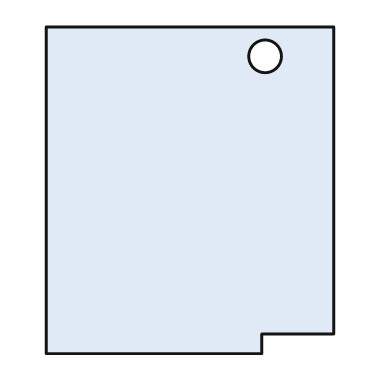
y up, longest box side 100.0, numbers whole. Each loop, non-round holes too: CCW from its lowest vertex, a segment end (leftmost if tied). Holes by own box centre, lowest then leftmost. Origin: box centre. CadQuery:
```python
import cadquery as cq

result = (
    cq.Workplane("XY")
    .moveTo(-44.0, -50.0)
    .lineTo(22.0, -50.0)
    .lineTo(22.0, -44.0)
    .lineTo(44.0, -44.0)
    .lineTo(44.0, 50.0)
    .lineTo(-44.0, 50.0)
    .close()
    .moveTo(23.0, 41.0)
    .circle(5.0)
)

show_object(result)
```